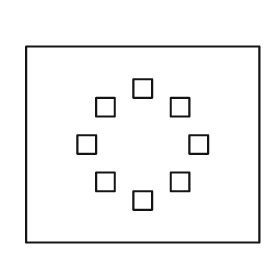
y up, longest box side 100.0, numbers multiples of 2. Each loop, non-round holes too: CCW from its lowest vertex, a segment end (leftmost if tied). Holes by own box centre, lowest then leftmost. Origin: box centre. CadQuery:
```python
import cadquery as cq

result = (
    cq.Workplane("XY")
    .moveTo(-50.0, -42.0)
    .lineTo(50.0, -42.0)
    .lineTo(50.0, 42.0)
    .lineTo(-50.0, 42.0)
    .close()
    .moveTo(-4.0, -28.0)
    .lineTo(4.0, -28.0)
    .lineTo(4.0, -20.0)
    .lineTo(-4.0, -20.0)
    .close()
    .moveTo(-20.0, -20.0)
    .lineTo(-12.0, -20.0)
    .lineTo(-12.0, -12.0)
    .lineTo(-20.0, -12.0)
    .close()
    .moveTo(12.0, -20.0)
    .lineTo(20.0, -20.0)
    .lineTo(20.0, -12.0)
    .lineTo(12.0, -12.0)
    .close()
    .moveTo(-28.0, -4.0)
    .lineTo(-20.0, -4.0)
    .lineTo(-20.0, 4.0)
    .lineTo(-28.0, 4.0)
    .close()
    .moveTo(20.0, -4.0)
    .lineTo(28.0, -4.0)
    .lineTo(28.0, 4.0)
    .lineTo(20.0, 4.0)
    .close()
    .moveTo(-20.0, 12.0)
    .lineTo(-12.0, 12.0)
    .lineTo(-12.0, 20.0)
    .lineTo(-20.0, 20.0)
    .close()
    .moveTo(12.0, 12.0)
    .lineTo(20.0, 12.0)
    .lineTo(20.0, 20.0)
    .lineTo(12.0, 20.0)
    .close()
    .moveTo(-4.0, 20.0)
    .lineTo(4.0, 20.0)
    .lineTo(4.0, 28.0)
    .lineTo(-4.0, 28.0)
    .close()
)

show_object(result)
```